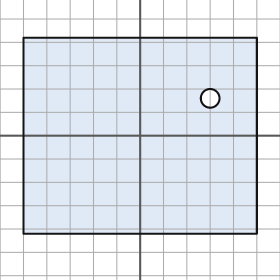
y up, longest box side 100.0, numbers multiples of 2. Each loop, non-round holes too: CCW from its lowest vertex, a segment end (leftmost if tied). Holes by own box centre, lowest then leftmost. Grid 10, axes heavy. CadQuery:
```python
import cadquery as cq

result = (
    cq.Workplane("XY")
    .moveTo(-50.0, -42.0)
    .lineTo(50.0, -42.0)
    .lineTo(50.0, 42.0)
    .lineTo(-50.0, 42.0)
    .close()
    .moveTo(30.0, 16.0)
    .circle(4.0)
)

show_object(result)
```